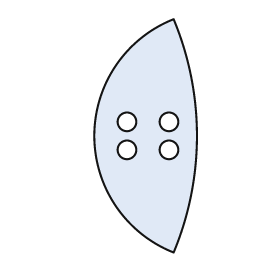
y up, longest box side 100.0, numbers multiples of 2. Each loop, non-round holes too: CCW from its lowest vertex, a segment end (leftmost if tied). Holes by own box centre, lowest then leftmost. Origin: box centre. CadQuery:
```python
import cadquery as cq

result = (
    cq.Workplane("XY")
    .moveTo(12.0, -50.0)
    .threePointArc((22.0, 0.0), (12.0, 50.0))
    .threePointArc((-22.0, 0.0), (12.0, -50.0))
    .close()
    .moveTo(-8.0, -6.0)
    .circle(4.0)
    .moveTo(10.0, -6.0)
    .circle(4.0)
    .moveTo(-8.0, 6.0)
    .circle(4.0)
    .moveTo(10.0, 6.0)
    .circle(4.0)
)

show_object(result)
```